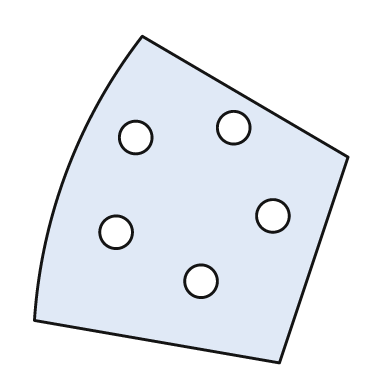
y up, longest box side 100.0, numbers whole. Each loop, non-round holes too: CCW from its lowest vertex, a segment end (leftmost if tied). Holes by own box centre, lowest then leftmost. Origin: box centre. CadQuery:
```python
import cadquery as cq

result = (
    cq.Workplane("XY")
    .moveTo(27.0, -50.0)
    .lineTo(48.0, 13.0)
    .lineTo(-15.0, 50.0)
    .threePointArc((-38.0, 9.0), (-48.0, -37.0))
    .close()
    .moveTo(3.0, -25.0)
    .circle(5.0)
    .moveTo(-23.0, -10.0)
    .circle(5.0)
    .moveTo(25.0, -5.0)
    .circle(5.0)
    .moveTo(-17.0, 19.0)
    .circle(5.0)
    .moveTo(13.0, 22.0)
    .circle(5.0)
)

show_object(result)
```